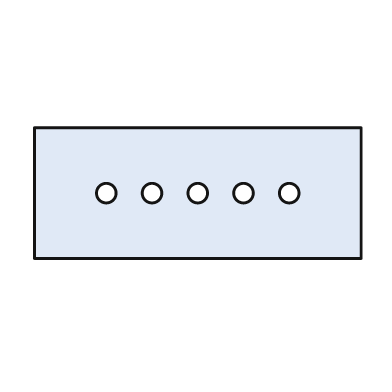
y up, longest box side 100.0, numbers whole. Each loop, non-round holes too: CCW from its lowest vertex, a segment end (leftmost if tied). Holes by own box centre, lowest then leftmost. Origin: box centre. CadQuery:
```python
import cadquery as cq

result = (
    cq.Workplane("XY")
    .moveTo(-50.0, -20.0)
    .lineTo(50.0, -20.0)
    .lineTo(50.0, 20.0)
    .lineTo(-50.0, 20.0)
    .close()
    .moveTo(-28.0, 0.0)
    .circle(3.0)
    .moveTo(-14.0, 0.0)
    .circle(3.0)
    .moveTo(0.0, 0.0)
    .circle(3.0)
    .moveTo(14.0, 0.0)
    .circle(3.0)
    .moveTo(28.0, 0.0)
    .circle(3.0)
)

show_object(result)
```